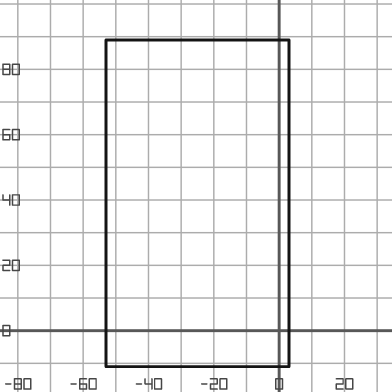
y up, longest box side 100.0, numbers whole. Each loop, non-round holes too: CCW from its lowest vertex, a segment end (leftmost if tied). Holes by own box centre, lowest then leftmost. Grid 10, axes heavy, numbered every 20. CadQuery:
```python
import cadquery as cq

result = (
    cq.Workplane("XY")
    .moveTo(-53.0, -11.0)
    .lineTo(3.0, -11.0)
    .lineTo(3.0, 89.0)
    .lineTo(-53.0, 89.0)
    .close()
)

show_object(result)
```